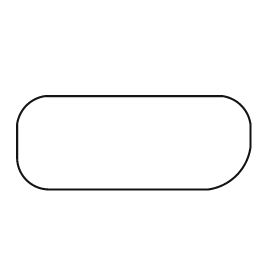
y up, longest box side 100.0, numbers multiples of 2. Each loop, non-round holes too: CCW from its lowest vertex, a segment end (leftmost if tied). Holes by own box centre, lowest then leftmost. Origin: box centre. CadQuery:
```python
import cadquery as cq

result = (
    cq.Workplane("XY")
    .moveTo(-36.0, -20.0)
    .lineTo(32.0, -20.0)
    .threePointArc((44.0, -14.0), (50.0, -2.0))
    .lineTo(50.0, 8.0)
    .threePointArc((46.0, 16.0), (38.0, 20.0))
    .lineTo(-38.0, 20.0)
    .threePointArc((-46.0, 16.0), (-50.0, 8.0))
    .lineTo(-50.0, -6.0)
    .threePointArc((-46.0, -16.0), (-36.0, -20.0))
    .close()
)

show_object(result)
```